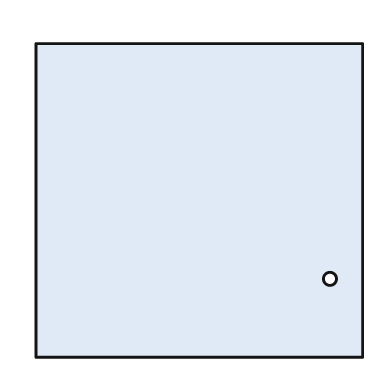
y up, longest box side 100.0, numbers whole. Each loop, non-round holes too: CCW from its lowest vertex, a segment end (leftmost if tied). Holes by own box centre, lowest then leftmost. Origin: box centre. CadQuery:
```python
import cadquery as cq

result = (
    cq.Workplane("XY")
    .moveTo(-50.0, -48.0)
    .lineTo(50.0, -48.0)
    .lineTo(50.0, 48.0)
    .lineTo(-50.0, 48.0)
    .close()
    .moveTo(40.0, -24.0)
    .circle(2.0)
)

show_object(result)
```